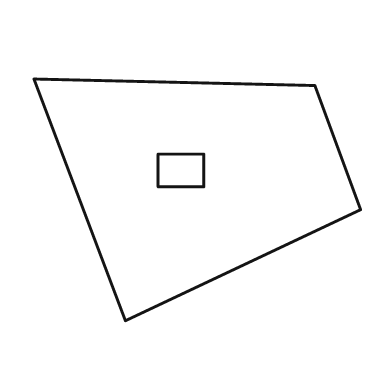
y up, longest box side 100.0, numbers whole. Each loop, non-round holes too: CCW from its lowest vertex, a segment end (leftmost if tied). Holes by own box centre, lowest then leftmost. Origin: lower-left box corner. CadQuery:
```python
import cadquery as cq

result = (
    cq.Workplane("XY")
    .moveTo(28.0, 0.0)
    .lineTo(100.0, 34.0)
    .lineTo(86.0, 72.0)
    .lineTo(0.0, 74.0)
    .close()
    .moveTo(38.0, 41.0)
    .lineTo(52.0, 41.0)
    .lineTo(52.0, 51.0)
    .lineTo(38.0, 51.0)
    .close()
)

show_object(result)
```